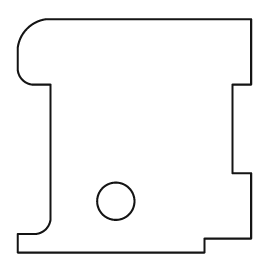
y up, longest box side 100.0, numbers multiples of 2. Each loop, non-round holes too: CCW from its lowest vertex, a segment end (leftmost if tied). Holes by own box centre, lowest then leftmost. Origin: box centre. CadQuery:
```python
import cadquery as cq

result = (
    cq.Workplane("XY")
    .moveTo(-50.0, -50.0)
    .lineTo(30.0, -50.0)
    .lineTo(30.0, -44.0)
    .lineTo(50.0, -44.0)
    .lineTo(50.0, -16.0)
    .lineTo(42.0, -16.0)
    .lineTo(42.0, 22.0)
    .lineTo(50.0, 22.0)
    .lineTo(50.0, 50.0)
    .lineTo(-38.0, 50.0)
    .threePointArc((-46.0, 46.0), (-50.0, 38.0))
    .lineTo(-50.0, 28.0)
    .threePointArc((-48.0, 24.0), (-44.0, 22.0))
    .lineTo(-36.0, 22.0)
    .lineTo(-36.0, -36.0)
    .threePointArc((-38.0, -40.0), (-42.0, -42.0))
    .lineTo(-50.0, -42.0)
    .close()
    .moveTo(-8.0, -28.0)
    .circle(8.0)
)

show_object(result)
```